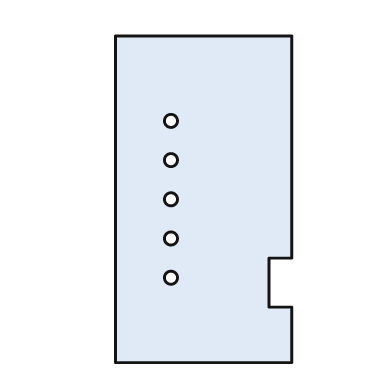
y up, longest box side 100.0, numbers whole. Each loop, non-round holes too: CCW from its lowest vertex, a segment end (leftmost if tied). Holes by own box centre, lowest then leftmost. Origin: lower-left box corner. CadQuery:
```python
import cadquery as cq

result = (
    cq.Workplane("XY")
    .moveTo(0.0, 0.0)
    .lineTo(54.0, 0.0)
    .lineTo(54.0, 17.0)
    .lineTo(47.0, 17.0)
    .lineTo(47.0, 32.0)
    .lineTo(54.0, 32.0)
    .lineTo(54.0, 100.0)
    .lineTo(0.0, 100.0)
    .close()
    .moveTo(17.0, 26.0)
    .circle(2.0)
    .moveTo(17.0, 38.0)
    .circle(2.0)
    .moveTo(17.0, 50.0)
    .circle(2.0)
    .moveTo(17.0, 62.0)
    .circle(2.0)
    .moveTo(17.0, 74.0)
    .circle(2.0)
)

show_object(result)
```